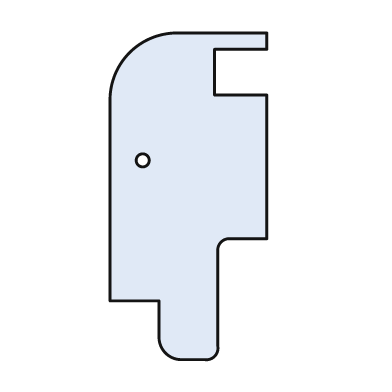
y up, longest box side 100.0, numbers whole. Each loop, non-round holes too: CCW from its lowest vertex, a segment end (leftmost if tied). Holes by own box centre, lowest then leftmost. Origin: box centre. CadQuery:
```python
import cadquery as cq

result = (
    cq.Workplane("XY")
    .moveTo(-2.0, -50.0)
    .lineTo(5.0, -50.0)
    .threePointArc((8.0, -49.0), (9.0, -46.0))
    .lineTo(9.0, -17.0)
    .threePointArc((10.0, -14.0), (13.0, -13.0))
    .lineTo(24.0, -13.0)
    .lineTo(24.0, 31.0)
    .lineTo(8.0, 31.0)
    .lineTo(8.0, 45.0)
    .lineTo(24.0, 45.0)
    .lineTo(24.0, 50.0)
    .lineTo(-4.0, 50.0)
    .threePointArc((-18.0, 44.0), (-24.0, 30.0))
    .lineTo(-24.0, -32.0)
    .lineTo(-9.0, -32.0)
    .lineTo(-9.0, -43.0)
    .threePointArc((-7.0, -48.0), (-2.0, -50.0))
    .close()
    .moveTo(-14.0, 11.0)
    .circle(2.0)
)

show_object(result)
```